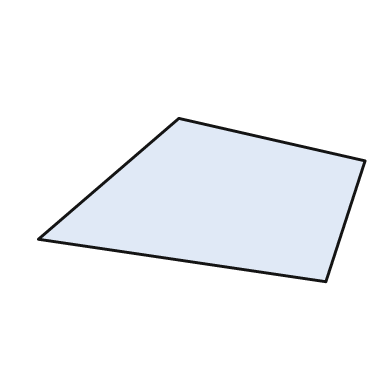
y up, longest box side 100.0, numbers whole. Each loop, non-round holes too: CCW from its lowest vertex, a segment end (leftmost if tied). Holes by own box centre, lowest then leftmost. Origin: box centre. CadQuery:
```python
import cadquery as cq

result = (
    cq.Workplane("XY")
    .moveTo(38.0, -25.0)
    .lineTo(50.0, 12.0)
    .lineTo(-7.0, 25.0)
    .lineTo(-50.0, -12.0)
    .close()
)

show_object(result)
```